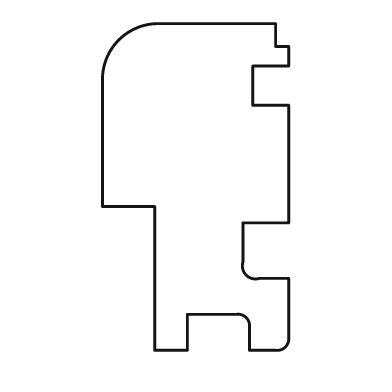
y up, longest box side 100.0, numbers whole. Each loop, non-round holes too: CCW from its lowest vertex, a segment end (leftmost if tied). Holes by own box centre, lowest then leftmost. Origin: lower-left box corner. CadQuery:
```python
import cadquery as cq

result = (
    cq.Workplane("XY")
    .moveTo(16.0, 0.0)
    .lineTo(26.0, 0.0)
    .lineTo(26.0, 11.0)
    .lineTo(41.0, 11.0)
    .threePointArc((44.0, 10.0), (45.0, 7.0))
    .lineTo(45.0, 0.0)
    .lineTo(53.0, 0.0)
    .threePointArc((56.0, 1.0), (57.0, 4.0))
    .lineTo(57.0, 22.0)
    .lineTo(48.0, 22.0)
    .threePointArc((44.0, 23.0), (43.0, 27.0))
    .lineTo(43.0, 39.0)
    .lineTo(57.0, 39.0)
    .lineTo(57.0, 75.0)
    .lineTo(46.0, 75.0)
    .lineTo(46.0, 87.0)
    .lineTo(57.0, 87.0)
    .lineTo(57.0, 93.0)
    .lineTo(53.0, 93.0)
    .lineTo(53.0, 100.0)
    .lineTo(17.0, 100.0)
    .threePointArc((5.0, 95.0), (0.0, 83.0))
    .lineTo(0.0, 44.0)
    .lineTo(16.0, 44.0)
    .close()
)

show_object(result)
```